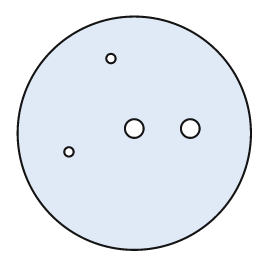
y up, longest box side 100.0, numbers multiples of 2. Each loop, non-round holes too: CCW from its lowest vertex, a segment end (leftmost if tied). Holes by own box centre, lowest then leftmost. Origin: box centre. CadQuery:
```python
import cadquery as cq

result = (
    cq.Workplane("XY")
    .moveTo(0.0, 0.0)
    .circle(50.0)
    .moveTo(-28.0, -8.0)
    .circle(2.0)
    .moveTo(0.0, 2.0)
    .circle(4.0)
    .moveTo(24.0, 2.0)
    .circle(4.0)
    .moveTo(-10.0, 32.0)
    .circle(2.0)
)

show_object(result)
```